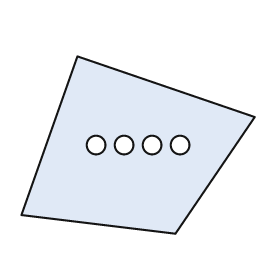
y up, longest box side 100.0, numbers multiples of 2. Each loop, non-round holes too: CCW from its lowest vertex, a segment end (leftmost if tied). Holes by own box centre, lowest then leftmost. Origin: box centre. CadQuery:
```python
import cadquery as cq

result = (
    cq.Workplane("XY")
    .moveTo(16.0, -38.0)
    .lineTo(50.0, 12.0)
    .lineTo(-26.0, 38.0)
    .lineTo(-50.0, -30.0)
    .close()
    .moveTo(-18.0, 0.0)
    .circle(4.0)
    .moveTo(-6.0, 0.0)
    .circle(4.0)
    .moveTo(6.0, 0.0)
    .circle(4.0)
    .moveTo(18.0, 0.0)
    .circle(4.0)
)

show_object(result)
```